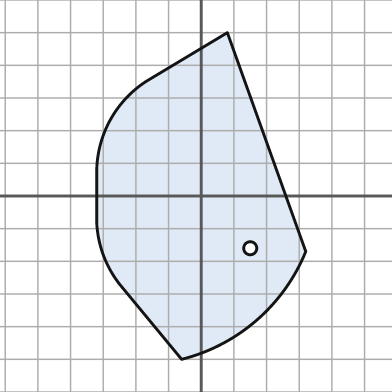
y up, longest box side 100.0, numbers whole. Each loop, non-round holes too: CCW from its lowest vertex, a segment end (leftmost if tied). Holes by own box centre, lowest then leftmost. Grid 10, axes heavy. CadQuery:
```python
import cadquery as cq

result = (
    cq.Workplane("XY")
    .moveTo(-6.0, -50.0)
    .threePointArc((17.0, -38.0), (32.0, -17.0))
    .lineTo(8.0, 50.0)
    .lineTo(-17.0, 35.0)
    .threePointArc((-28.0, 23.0), (-32.0, 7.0))
    .lineTo(-32.0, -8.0)
    .threePointArc((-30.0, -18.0), (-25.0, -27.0))
    .close()
    .moveTo(15.0, -16.0)
    .circle(2.0)
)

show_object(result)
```